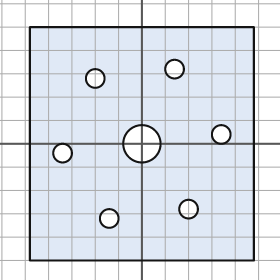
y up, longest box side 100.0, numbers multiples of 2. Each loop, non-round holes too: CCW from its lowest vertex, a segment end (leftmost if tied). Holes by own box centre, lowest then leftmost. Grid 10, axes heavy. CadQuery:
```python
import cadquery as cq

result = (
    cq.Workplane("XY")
    .moveTo(-48.0, -50.0)
    .lineTo(48.0, -50.0)
    .lineTo(48.0, 50.0)
    .lineTo(-48.0, 50.0)
    .close()
    .moveTo(-14.0, -32.0)
    .circle(4.0)
    .moveTo(20.0, -28.0)
    .circle(4.0)
    .moveTo(-34.0, -4.0)
    .circle(4.0)
    .moveTo(0.0, 0.0)
    .circle(8.0)
    .moveTo(34.0, 4.0)
    .circle(4.0)
    .moveTo(-20.0, 28.0)
    .circle(4.0)
    .moveTo(14.0, 32.0)
    .circle(4.0)
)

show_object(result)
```